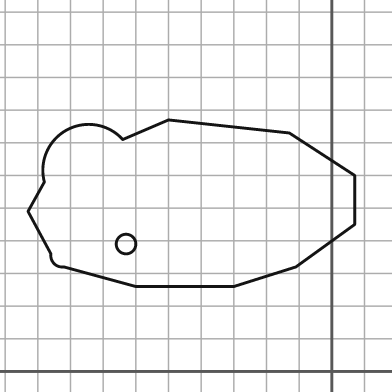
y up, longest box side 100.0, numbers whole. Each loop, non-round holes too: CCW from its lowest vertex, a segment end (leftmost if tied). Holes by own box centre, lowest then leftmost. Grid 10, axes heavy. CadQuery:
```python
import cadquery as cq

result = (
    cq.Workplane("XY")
    .moveTo(-60.0, 26.0)
    .lineTo(-30.0, 26.0)
    .lineTo(-11.0, 32.0)
    .lineTo(7.0, 45.0)
    .lineTo(7.0, 60.0)
    .lineTo(-13.0, 73.0)
    .lineTo(-50.0, 77.0)
    .lineTo(-64.0, 71.0)
    .threePointArc((-81.0, 74.0), (-88.0, 58.0))
    .lineTo(-93.0, 49.0)
    .lineTo(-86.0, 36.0)
    .threePointArc((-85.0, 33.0), (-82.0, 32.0))
    .close()
    .moveTo(-63.0, 39.0)
    .circle(3.0)
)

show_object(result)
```